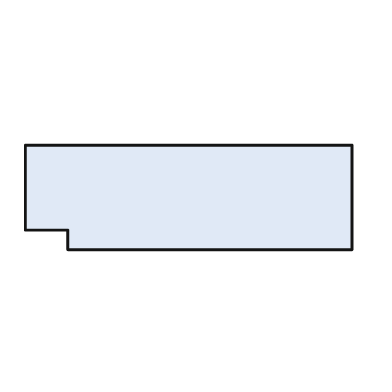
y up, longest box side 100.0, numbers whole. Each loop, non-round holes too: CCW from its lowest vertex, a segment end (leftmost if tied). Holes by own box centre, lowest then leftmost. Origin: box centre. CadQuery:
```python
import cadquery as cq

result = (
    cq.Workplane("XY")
    .moveTo(-37.0, -16.0)
    .lineTo(50.0, -16.0)
    .lineTo(50.0, 16.0)
    .lineTo(-50.0, 16.0)
    .lineTo(-50.0, -10.0)
    .lineTo(-37.0, -10.0)
    .close()
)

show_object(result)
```